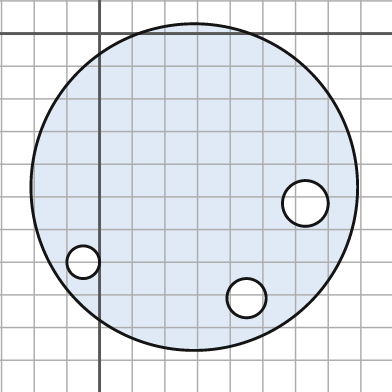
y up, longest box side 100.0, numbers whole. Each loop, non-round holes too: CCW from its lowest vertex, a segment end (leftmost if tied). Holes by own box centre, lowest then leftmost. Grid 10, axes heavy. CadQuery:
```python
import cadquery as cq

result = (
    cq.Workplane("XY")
    .moveTo(29.0, -47.0)
    .circle(50.0)
    .moveTo(45.0, -81.0)
    .circle(6.0)
    .moveTo(-5.0, -70.0)
    .circle(5.0)
    .moveTo(63.0, -52.0)
    .circle(7.0)
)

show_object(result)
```